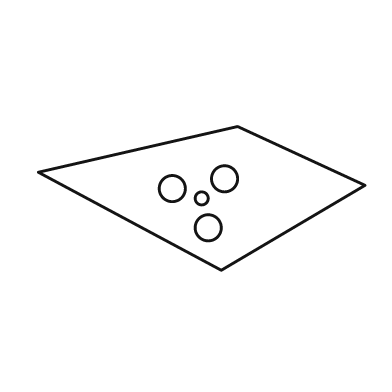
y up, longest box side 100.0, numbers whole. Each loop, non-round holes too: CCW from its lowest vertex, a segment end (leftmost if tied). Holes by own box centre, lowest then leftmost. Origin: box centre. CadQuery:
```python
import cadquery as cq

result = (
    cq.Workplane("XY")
    .moveTo(6.0, -22.0)
    .lineTo(50.0, 4.0)
    .lineTo(11.0, 22.0)
    .lineTo(-50.0, 8.0)
    .close()
    .moveTo(2.0, -9.0)
    .circle(4.0)
    .moveTo(0.0, 0.0)
    .circle(2.0)
    .moveTo(-9.0, 3.0)
    .circle(4.0)
    .moveTo(7.0, 6.0)
    .circle(4.0)
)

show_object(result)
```